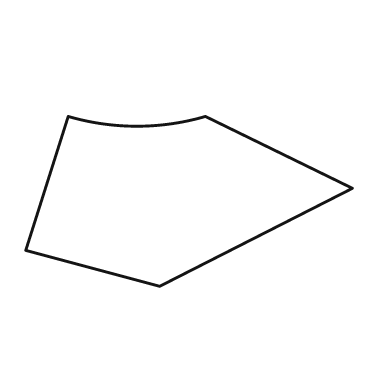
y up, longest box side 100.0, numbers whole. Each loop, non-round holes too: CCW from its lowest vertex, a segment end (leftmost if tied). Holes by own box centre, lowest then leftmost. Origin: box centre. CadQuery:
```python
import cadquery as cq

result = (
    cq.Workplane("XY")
    .moveTo(-9.0, -26.0)
    .lineTo(50.0, 4.0)
    .lineTo(5.0, 26.0)
    .threePointArc((-16.0, 23.0), (-37.0, 26.0))
    .lineTo(-50.0, -15.0)
    .close()
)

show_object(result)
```